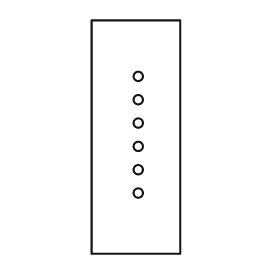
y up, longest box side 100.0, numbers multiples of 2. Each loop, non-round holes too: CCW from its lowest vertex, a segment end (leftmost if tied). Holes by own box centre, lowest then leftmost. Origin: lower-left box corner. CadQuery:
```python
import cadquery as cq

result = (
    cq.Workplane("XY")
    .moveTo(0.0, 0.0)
    .lineTo(38.0, 0.0)
    .lineTo(38.0, 100.0)
    .lineTo(0.0, 100.0)
    .close()
    .moveTo(20.0, 26.0)
    .circle(2.0)
    .moveTo(20.0, 36.0)
    .circle(2.0)
    .moveTo(20.0, 46.0)
    .circle(2.0)
    .moveTo(20.0, 56.0)
    .circle(2.0)
    .moveTo(20.0, 66.0)
    .circle(2.0)
    .moveTo(20.0, 76.0)
    .circle(2.0)
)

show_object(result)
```